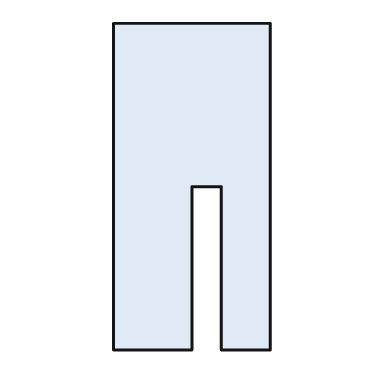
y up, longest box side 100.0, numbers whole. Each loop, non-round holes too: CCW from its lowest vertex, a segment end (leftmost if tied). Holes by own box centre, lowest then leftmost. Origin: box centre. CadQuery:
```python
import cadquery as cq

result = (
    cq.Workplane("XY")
    .moveTo(-24.0, -50.0)
    .lineTo(0.0, -50.0)
    .lineTo(0.0, 0.0)
    .lineTo(9.0, 0.0)
    .lineTo(9.0, -50.0)
    .lineTo(24.0, -50.0)
    .lineTo(24.0, 50.0)
    .lineTo(-24.0, 50.0)
    .close()
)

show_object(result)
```